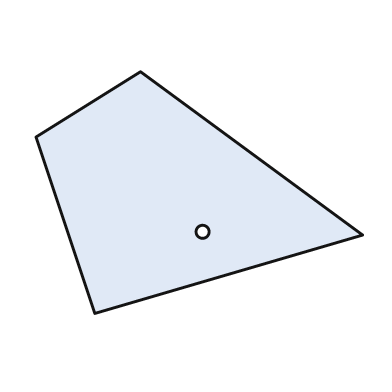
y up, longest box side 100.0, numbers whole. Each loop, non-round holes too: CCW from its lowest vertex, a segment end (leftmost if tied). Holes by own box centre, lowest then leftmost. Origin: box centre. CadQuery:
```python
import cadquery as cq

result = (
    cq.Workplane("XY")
    .moveTo(-32.0, -37.0)
    .lineTo(50.0, -13.0)
    .lineTo(-18.0, 37.0)
    .lineTo(-50.0, 17.0)
    .close()
    .moveTo(1.0, -12.0)
    .circle(2.0)
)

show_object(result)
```